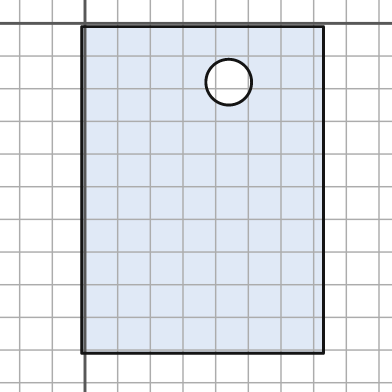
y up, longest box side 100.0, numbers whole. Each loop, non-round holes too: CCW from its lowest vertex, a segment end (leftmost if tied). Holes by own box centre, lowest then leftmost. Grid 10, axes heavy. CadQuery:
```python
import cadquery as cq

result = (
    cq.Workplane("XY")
    .moveTo(-1.0, -101.0)
    .lineTo(73.0, -101.0)
    .lineTo(73.0, -1.0)
    .lineTo(-1.0, -1.0)
    .close()
    .moveTo(44.0, -18.0)
    .circle(7.0)
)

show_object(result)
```